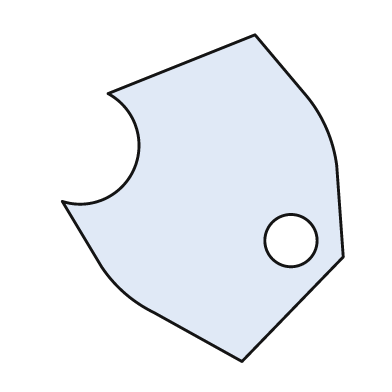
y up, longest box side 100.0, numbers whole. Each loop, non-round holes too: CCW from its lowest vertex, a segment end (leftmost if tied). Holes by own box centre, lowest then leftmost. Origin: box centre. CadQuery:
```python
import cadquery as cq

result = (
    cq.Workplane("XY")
    .moveTo(12.0, -50.0)
    .lineTo(43.0, -18.0)
    .lineTo(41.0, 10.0)
    .threePointArc((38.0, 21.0), (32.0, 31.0))
    .lineTo(16.0, 50.0)
    .lineTo(-29.0, 32.0)
    .threePointArc((-21.0, 9.0), (-43.0, -1.0))
    .lineTo(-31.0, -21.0)
    .threePointArc((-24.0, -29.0), (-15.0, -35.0))
    .close()
    .moveTo(27.0, -13.0)
    .circle(8.0)
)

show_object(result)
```